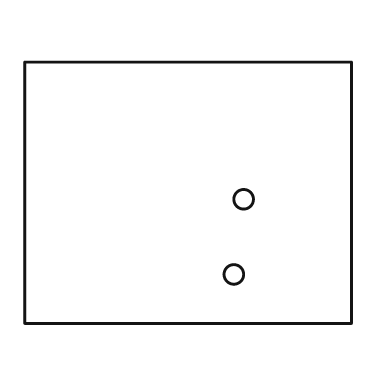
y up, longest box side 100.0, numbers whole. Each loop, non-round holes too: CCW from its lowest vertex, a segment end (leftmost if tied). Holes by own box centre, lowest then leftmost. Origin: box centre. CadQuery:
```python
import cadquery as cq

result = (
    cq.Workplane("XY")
    .moveTo(-50.0, -40.0)
    .lineTo(50.0, -40.0)
    .lineTo(50.0, 40.0)
    .lineTo(-50.0, 40.0)
    .close()
    .moveTo(14.0, -25.0)
    .circle(3.0)
    .moveTo(17.0, -2.0)
    .circle(3.0)
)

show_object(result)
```